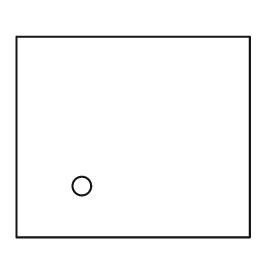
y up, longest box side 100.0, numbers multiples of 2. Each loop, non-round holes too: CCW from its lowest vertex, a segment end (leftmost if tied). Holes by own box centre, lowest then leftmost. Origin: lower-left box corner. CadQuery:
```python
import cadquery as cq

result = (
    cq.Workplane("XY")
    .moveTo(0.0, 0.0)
    .lineTo(100.0, 0.0)
    .lineTo(100.0, 86.0)
    .lineTo(0.0, 86.0)
    .close()
    .moveTo(28.0, 22.0)
    .circle(4.0)
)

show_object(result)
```